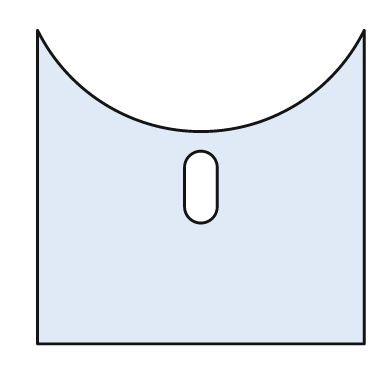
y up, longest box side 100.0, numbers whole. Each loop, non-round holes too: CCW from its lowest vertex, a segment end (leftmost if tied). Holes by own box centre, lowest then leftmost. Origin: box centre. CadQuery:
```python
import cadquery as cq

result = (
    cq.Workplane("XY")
    .moveTo(-50.0, -48.0)
    .lineTo(50.0, -48.0)
    .lineTo(50.0, 48.0)
    .threePointArc((0.0, 17.0), (-50.0, 48.0))
    .close()
    .moveTo(-5.0, -6.0)
    .threePointArc((0.0, -11.0), (5.0, -6.0))
    .lineTo(5.0, 6.0)
    .threePointArc((0.0, 11.0), (-5.0, 6.0))
    .close()
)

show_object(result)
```